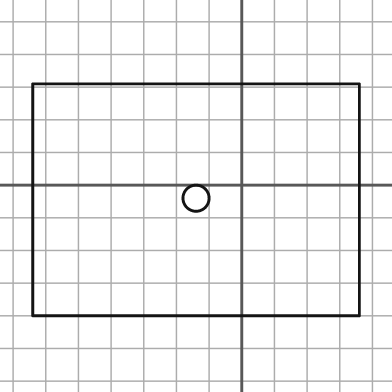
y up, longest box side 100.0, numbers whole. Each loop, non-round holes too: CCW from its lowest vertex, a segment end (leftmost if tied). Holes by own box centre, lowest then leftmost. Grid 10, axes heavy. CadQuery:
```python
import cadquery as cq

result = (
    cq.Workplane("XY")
    .moveTo(-64.0, -40.0)
    .lineTo(36.0, -40.0)
    .lineTo(36.0, 31.0)
    .lineTo(-64.0, 31.0)
    .close()
    .moveTo(-14.0, -4.0)
    .circle(4.0)
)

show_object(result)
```